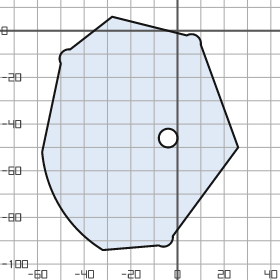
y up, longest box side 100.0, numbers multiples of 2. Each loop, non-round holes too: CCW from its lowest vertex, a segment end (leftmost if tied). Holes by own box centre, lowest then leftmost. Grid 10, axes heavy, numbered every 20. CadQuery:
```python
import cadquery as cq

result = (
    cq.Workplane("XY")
    .moveTo(-32.0, -94.0)
    .lineTo(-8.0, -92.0)
    .threePointArc((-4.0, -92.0), (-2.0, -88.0))
    .lineTo(26.0, -50.0)
    .lineTo(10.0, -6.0)
    .threePointArc((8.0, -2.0), (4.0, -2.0))
    .lineTo(-28.0, 6.0)
    .lineTo(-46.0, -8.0)
    .threePointArc((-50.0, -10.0), (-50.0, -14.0))
    .lineTo(-58.0, -52.0)
    .threePointArc((-50.0, -76.0), (-32.0, -94.0))
    .close()
    .moveTo(-4.0, -46.0)
    .circle(4.0)
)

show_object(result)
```